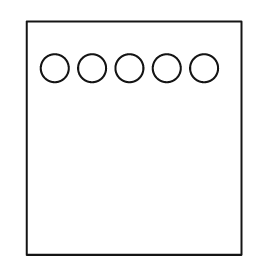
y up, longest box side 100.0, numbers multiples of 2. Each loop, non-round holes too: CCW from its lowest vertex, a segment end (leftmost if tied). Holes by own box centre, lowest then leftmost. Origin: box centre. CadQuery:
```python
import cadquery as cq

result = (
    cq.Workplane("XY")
    .moveTo(-46.0, -50.0)
    .lineTo(46.0, -50.0)
    .lineTo(46.0, 50.0)
    .lineTo(-46.0, 50.0)
    .close()
    .moveTo(-34.0, 30.0)
    .circle(6.0)
    .moveTo(-18.0, 30.0)
    .circle(6.0)
    .moveTo(-2.0, 30.0)
    .circle(6.0)
    .moveTo(14.0, 30.0)
    .circle(6.0)
    .moveTo(30.0, 30.0)
    .circle(6.0)
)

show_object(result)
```